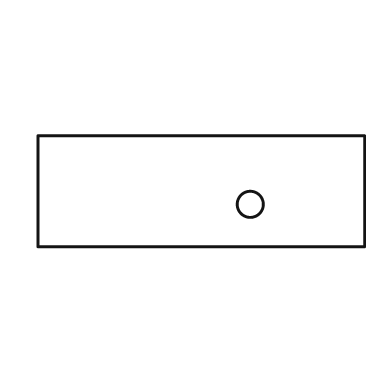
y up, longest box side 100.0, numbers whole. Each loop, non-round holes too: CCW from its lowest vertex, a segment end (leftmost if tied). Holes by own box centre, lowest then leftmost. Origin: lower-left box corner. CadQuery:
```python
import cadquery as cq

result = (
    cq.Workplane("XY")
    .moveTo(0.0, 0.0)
    .lineTo(100.0, 0.0)
    .lineTo(100.0, 34.0)
    .lineTo(0.0, 34.0)
    .close()
    .moveTo(65.0, 13.0)
    .circle(4.0)
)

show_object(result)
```